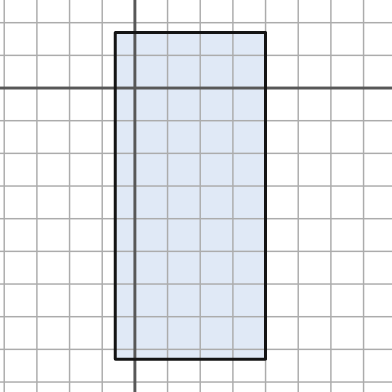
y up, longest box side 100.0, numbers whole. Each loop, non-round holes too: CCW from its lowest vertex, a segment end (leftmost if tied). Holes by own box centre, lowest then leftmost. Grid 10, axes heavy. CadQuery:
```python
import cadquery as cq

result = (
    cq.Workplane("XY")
    .moveTo(-6.0, -83.0)
    .lineTo(40.0, -83.0)
    .lineTo(40.0, 17.0)
    .lineTo(-6.0, 17.0)
    .close()
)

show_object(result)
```